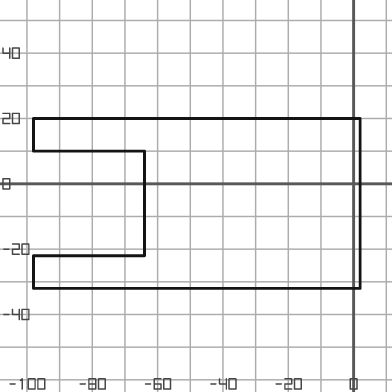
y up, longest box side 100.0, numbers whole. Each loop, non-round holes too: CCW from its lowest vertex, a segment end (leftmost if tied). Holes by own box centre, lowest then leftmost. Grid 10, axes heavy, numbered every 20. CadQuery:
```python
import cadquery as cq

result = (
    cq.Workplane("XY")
    .moveTo(-98.0, -32.0)
    .lineTo(2.0, -32.0)
    .lineTo(2.0, 20.0)
    .lineTo(-98.0, 20.0)
    .lineTo(-98.0, 10.0)
    .lineTo(-64.0, 10.0)
    .lineTo(-64.0, -22.0)
    .lineTo(-98.0, -22.0)
    .close()
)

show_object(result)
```